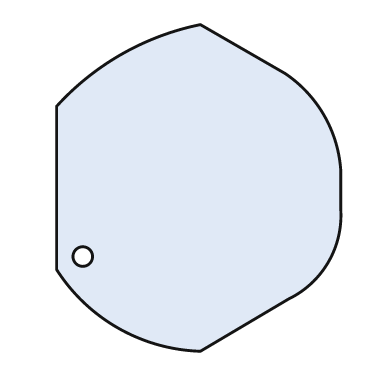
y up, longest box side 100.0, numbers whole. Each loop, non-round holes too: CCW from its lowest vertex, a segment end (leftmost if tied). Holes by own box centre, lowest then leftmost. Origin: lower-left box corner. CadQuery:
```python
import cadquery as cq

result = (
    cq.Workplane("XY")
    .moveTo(44.0, 0.0)
    .lineTo(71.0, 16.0)
    .threePointArc((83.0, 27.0), (87.0, 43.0))
    .lineTo(87.0, 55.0)
    .threePointArc((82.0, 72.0), (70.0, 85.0))
    .lineTo(44.0, 100.0)
    .threePointArc((20.0, 91.0), (0.0, 75.0))
    .lineTo(0.0, 25.0)
    .threePointArc((19.0, 7.0), (44.0, 0.0))
    .close()
    .moveTo(8.0, 29.0)
    .circle(3.0)
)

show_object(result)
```